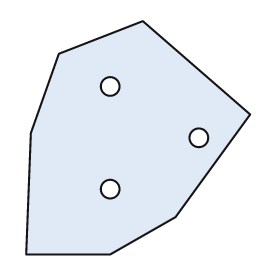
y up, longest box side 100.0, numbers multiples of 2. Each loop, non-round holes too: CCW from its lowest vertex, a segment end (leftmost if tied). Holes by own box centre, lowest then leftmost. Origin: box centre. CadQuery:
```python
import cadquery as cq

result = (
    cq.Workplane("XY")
    .moveTo(-48.0, -50.0)
    .lineTo(-12.0, -50.0)
    .lineTo(16.0, -34.0)
    .lineTo(48.0, 10.0)
    .lineTo(2.0, 50.0)
    .lineTo(-34.0, 36.0)
    .lineTo(-46.0, 2.0)
    .close()
    .moveTo(-12.0, -22.0)
    .circle(4.0)
    .moveTo(26.0, 0.0)
    .circle(4.0)
    .moveTo(-12.0, 22.0)
    .circle(4.0)
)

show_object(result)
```